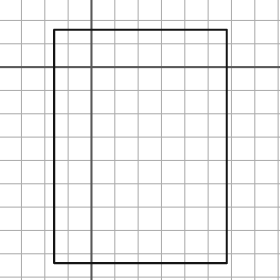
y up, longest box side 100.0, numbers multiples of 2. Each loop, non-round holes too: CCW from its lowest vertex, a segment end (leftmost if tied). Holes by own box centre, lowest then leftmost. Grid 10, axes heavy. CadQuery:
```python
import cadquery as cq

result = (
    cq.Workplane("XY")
    .moveTo(-16.0, -84.0)
    .lineTo(58.0, -84.0)
    .lineTo(58.0, 16.0)
    .lineTo(-16.0, 16.0)
    .close()
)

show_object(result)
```